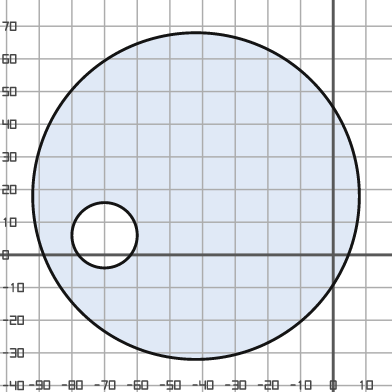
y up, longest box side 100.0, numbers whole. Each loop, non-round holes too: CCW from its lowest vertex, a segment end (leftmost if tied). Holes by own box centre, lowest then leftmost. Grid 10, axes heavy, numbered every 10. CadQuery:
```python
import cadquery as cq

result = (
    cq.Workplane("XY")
    .moveTo(-42.0, 18.0)
    .circle(50.0)
    .moveTo(-70.0, 6.0)
    .circle(10.0)
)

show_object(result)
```